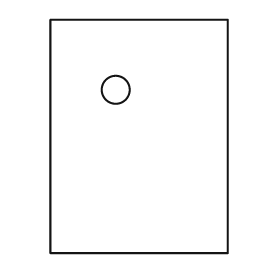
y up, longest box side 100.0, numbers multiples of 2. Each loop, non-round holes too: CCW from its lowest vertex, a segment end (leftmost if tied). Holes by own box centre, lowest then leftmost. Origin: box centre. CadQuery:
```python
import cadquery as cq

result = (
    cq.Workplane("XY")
    .moveTo(-38.0, -50.0)
    .lineTo(38.0, -50.0)
    .lineTo(38.0, 50.0)
    .lineTo(-38.0, 50.0)
    .close()
    .moveTo(-10.0, 20.0)
    .circle(6.0)
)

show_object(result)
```